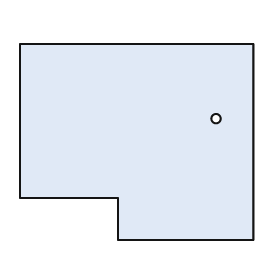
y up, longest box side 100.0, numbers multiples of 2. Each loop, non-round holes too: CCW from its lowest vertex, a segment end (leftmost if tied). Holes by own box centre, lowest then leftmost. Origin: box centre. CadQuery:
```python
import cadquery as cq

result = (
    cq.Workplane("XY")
    .moveTo(-8.0, -42.0)
    .lineTo(50.0, -42.0)
    .lineTo(50.0, 42.0)
    .lineTo(-50.0, 42.0)
    .lineTo(-50.0, -24.0)
    .lineTo(-8.0, -24.0)
    .close()
    .moveTo(34.0, 10.0)
    .circle(2.0)
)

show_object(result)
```